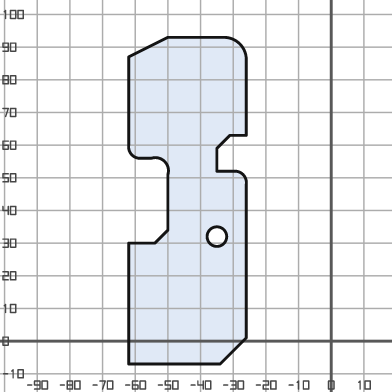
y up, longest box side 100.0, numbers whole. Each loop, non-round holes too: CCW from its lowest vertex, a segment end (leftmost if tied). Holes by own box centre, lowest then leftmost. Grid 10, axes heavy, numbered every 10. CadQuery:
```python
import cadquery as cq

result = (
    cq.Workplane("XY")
    .moveTo(-62.0, -7.0)
    .lineTo(-34.0, -7.0)
    .lineTo(-26.0, 1.0)
    .lineTo(-26.0, 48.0)
    .threePointArc((-27.0, 51.0), (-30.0, 52.0))
    .lineTo(-35.0, 52.0)
    .lineTo(-35.0, 59.0)
    .lineTo(-31.0, 63.0)
    .lineTo(-26.0, 63.0)
    .lineTo(-26.0, 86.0)
    .threePointArc((-28.0, 91.0), (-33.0, 93.0))
    .lineTo(-50.0, 93.0)
    .lineTo(-62.0, 87.0)
    .lineTo(-62.0, 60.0)
    .threePointArc((-61.0, 57.0), (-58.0, 56.0))
    .lineTo(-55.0, 56.0)
    .threePointArc((-51.0, 55.0), (-50.0, 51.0))
    .lineTo(-50.0, 34.0)
    .lineTo(-54.0, 30.0)
    .lineTo(-62.0, 30.0)
    .close()
    .moveTo(-35.0, 32.0)
    .circle(3.0)
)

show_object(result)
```